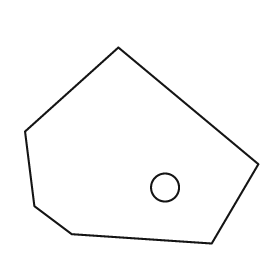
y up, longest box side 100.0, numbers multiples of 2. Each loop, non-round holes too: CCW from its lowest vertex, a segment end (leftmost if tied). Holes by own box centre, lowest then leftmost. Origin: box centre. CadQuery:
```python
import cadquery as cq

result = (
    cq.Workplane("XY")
    .moveTo(30.0, -42.0)
    .lineTo(50.0, -8.0)
    .lineTo(-10.0, 42.0)
    .lineTo(-50.0, 6.0)
    .lineTo(-46.0, -26.0)
    .lineTo(-30.0, -38.0)
    .close()
    .moveTo(10.0, -18.0)
    .circle(6.0)
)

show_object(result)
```